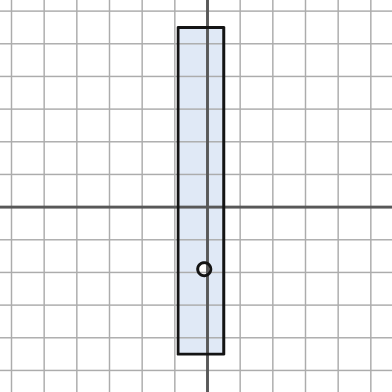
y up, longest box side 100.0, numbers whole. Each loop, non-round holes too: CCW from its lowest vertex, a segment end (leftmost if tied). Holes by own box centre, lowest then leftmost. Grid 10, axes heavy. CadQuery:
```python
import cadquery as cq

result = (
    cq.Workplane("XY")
    .moveTo(-9.0, -45.0)
    .lineTo(5.0, -45.0)
    .lineTo(5.0, 55.0)
    .lineTo(-9.0, 55.0)
    .close()
    .moveTo(-1.0, -19.0)
    .circle(2.0)
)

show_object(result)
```